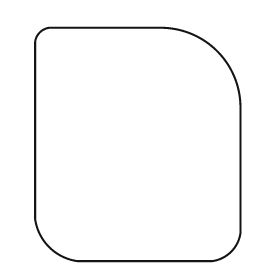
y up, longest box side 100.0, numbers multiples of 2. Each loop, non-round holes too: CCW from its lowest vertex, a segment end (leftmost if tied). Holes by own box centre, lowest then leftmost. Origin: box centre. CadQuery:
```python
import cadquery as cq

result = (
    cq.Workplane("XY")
    .moveTo(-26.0, -50.0)
    .lineTo(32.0, -50.0)
    .threePointArc((40.0, -46.0), (44.0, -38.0))
    .lineTo(44.0, 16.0)
    .threePointArc((34.0, 40.0), (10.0, 50.0))
    .lineTo(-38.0, 50.0)
    .threePointArc((-42.0, 48.0), (-44.0, 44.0))
    .lineTo(-44.0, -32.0)
    .threePointArc((-38.0, -44.0), (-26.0, -50.0))
    .close()
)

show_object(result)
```